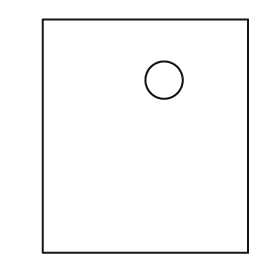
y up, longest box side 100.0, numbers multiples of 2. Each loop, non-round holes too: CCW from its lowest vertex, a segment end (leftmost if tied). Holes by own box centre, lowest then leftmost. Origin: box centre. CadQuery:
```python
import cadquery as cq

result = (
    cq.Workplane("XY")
    .moveTo(-44.0, -50.0)
    .lineTo(44.0, -50.0)
    .lineTo(44.0, 50.0)
    .lineTo(-44.0, 50.0)
    .close()
    .moveTo(8.0, 24.0)
    .circle(8.0)
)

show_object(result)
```